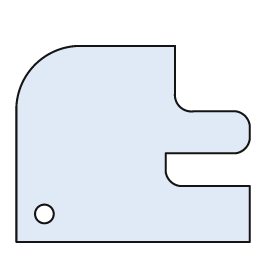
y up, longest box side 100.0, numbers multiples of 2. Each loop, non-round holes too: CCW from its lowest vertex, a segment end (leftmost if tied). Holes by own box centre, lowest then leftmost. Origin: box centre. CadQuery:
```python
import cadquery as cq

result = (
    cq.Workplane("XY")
    .moveTo(-50.0, -42.0)
    .lineTo(50.0, -42.0)
    .lineTo(50.0, -18.0)
    .lineTo(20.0, -18.0)
    .threePointArc((16.0, -16.0), (14.0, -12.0))
    .lineTo(14.0, -4.0)
    .lineTo(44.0, -4.0)
    .threePointArc((48.0, -2.0), (50.0, 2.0))
    .lineTo(50.0, 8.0)
    .threePointArc((48.0, 12.0), (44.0, 14.0))
    .lineTo(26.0, 14.0)
    .threePointArc((20.0, 16.0), (18.0, 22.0))
    .lineTo(18.0, 42.0)
    .lineTo(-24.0, 42.0)
    .threePointArc((-42.0, 34.0), (-50.0, 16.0))
    .close()
    .moveTo(-38.0, -30.0)
    .circle(4.0)
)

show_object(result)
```